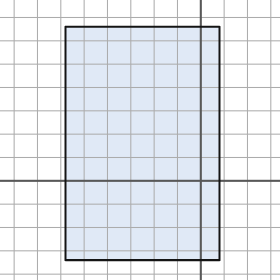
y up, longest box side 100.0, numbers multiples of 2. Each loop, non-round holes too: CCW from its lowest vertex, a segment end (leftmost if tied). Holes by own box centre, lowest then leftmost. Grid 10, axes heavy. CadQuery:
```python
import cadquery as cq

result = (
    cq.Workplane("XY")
    .moveTo(-58.0, -34.0)
    .lineTo(8.0, -34.0)
    .lineTo(8.0, 66.0)
    .lineTo(-58.0, 66.0)
    .close()
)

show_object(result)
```